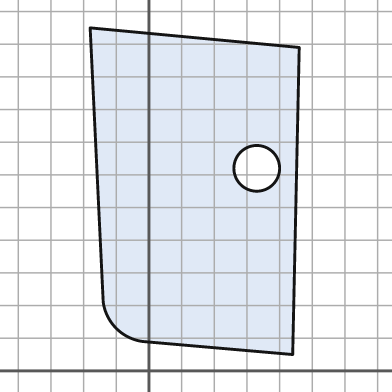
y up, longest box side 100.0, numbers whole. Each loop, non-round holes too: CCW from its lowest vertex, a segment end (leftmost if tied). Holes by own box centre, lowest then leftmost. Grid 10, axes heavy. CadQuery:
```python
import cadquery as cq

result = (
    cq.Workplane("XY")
    .moveTo(44.0, 5.0)
    .lineTo(46.0, 99.0)
    .lineTo(-18.0, 105.0)
    .lineTo(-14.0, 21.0)
    .threePointArc((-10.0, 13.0), (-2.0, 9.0))
    .close()
    .moveTo(33.0, 62.0)
    .circle(7.0)
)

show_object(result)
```